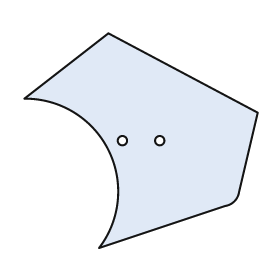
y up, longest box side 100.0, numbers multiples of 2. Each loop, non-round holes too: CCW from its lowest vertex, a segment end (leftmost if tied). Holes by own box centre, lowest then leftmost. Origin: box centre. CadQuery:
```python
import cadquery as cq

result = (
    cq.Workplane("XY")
    .moveTo(-18.0, -46.0)
    .lineTo(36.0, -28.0)
    .threePointArc((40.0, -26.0), (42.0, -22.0))
    .lineTo(50.0, 12.0)
    .lineTo(-14.0, 46.0)
    .lineTo(-50.0, 18.0)
    .threePointArc((-14.0, -4.0), (-18.0, -46.0))
    .close()
    .moveTo(-8.0, 0.0)
    .circle(2.0)
    .moveTo(8.0, 0.0)
    .circle(2.0)
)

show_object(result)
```